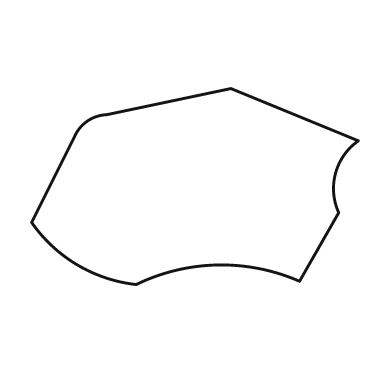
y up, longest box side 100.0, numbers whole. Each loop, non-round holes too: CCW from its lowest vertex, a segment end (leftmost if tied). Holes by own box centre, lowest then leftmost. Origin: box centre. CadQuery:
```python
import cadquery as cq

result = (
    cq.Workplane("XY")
    .moveTo(-18.0, -30.0)
    .threePointArc((7.0, -24.0), (32.0, -29.0))
    .lineTo(44.0, -8.0)
    .threePointArc((43.0, 4.0), (50.0, 14.0))
    .lineTo(11.0, 30.0)
    .lineTo(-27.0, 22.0)
    .threePointArc((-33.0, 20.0), (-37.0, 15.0))
    .lineTo(-50.0, -11.0)
    .threePointArc((-36.0, -24.0), (-18.0, -30.0))
    .close()
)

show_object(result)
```